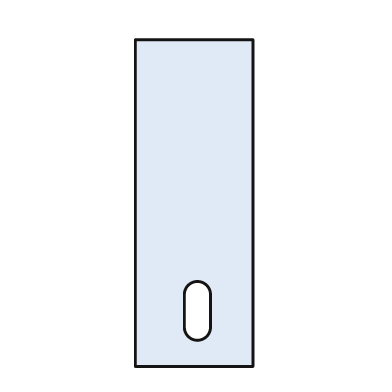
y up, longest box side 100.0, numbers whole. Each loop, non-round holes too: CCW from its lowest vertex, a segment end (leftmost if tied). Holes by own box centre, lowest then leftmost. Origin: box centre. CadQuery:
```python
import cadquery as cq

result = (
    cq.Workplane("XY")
    .moveTo(-18.0, -50.0)
    .lineTo(18.0, -50.0)
    .lineTo(18.0, 50.0)
    .lineTo(-18.0, 50.0)
    .close()
    .moveTo(-3.0, -38.0)
    .threePointArc((1.0, -42.0), (5.0, -38.0))
    .lineTo(5.0, -28.0)
    .threePointArc((1.0, -24.0), (-3.0, -28.0))
    .close()
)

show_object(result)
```